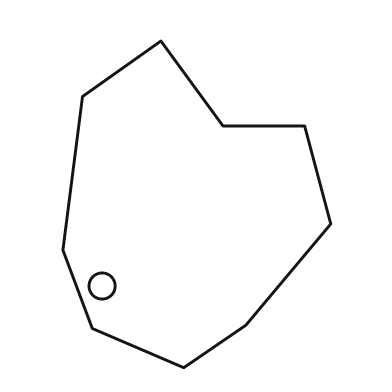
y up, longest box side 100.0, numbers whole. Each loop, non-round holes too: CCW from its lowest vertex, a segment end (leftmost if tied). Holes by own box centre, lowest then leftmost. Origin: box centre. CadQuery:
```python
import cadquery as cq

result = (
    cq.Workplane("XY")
    .moveTo(-4.0, -50.0)
    .lineTo(15.0, -37.0)
    .lineTo(41.0, -6.0)
    .lineTo(33.0, 24.0)
    .lineTo(8.0, 24.0)
    .lineTo(-11.0, 50.0)
    .lineTo(-35.0, 33.0)
    .lineTo(-41.0, -14.0)
    .lineTo(-32.0, -38.0)
    .close()
    .moveTo(-29.0, -25.0)
    .circle(4.0)
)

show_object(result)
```